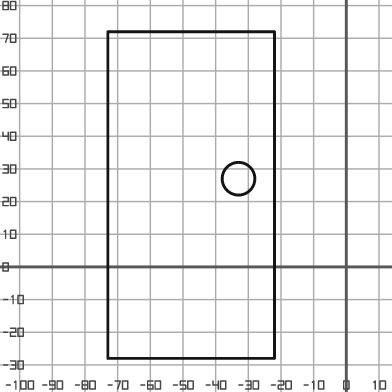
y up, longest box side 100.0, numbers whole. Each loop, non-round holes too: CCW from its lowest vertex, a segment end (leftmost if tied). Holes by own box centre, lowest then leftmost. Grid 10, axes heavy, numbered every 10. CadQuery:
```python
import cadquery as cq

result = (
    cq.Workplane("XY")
    .moveTo(-73.0, -28.0)
    .lineTo(-22.0, -28.0)
    .lineTo(-22.0, 72.0)
    .lineTo(-73.0, 72.0)
    .close()
    .moveTo(-33.0, 27.0)
    .circle(5.0)
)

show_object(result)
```